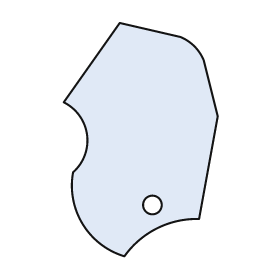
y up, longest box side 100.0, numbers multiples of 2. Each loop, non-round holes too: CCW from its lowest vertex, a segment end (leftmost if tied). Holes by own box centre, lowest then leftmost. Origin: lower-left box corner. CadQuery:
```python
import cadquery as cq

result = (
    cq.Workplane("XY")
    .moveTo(26.0, 0.0)
    .threePointArc((40.0, 12.0), (58.0, 16.0))
    .lineTo(66.0, 60.0)
    .lineTo(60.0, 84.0)
    .threePointArc((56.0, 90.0), (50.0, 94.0))
    .lineTo(24.0, 100.0)
    .lineTo(0.0, 66.0)
    .threePointArc((10.0, 52.0), (4.0, 36.0))
    .threePointArc((8.0, 14.0), (26.0, 0.0))
    .close()
    .moveTo(38.0, 22.0)
    .circle(4.0)
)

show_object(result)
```